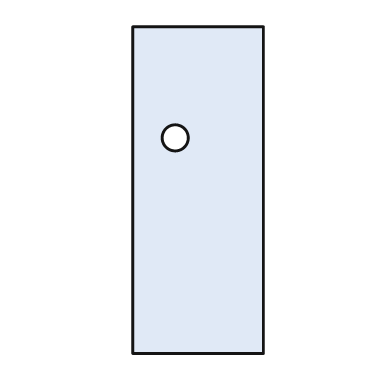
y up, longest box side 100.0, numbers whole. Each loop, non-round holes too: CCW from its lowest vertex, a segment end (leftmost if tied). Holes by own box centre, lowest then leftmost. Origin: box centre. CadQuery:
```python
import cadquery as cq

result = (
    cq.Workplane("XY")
    .moveTo(-20.0, -50.0)
    .lineTo(20.0, -50.0)
    .lineTo(20.0, 50.0)
    .lineTo(-20.0, 50.0)
    .close()
    .moveTo(-7.0, 16.0)
    .circle(4.0)
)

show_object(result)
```